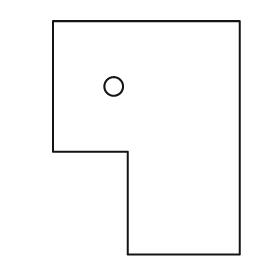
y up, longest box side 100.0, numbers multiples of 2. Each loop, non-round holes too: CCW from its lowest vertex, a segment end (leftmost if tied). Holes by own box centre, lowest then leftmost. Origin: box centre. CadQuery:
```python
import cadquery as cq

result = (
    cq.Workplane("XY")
    .moveTo(-8.0, -50.0)
    .lineTo(40.0, -50.0)
    .lineTo(40.0, 50.0)
    .lineTo(-40.0, 50.0)
    .lineTo(-40.0, -6.0)
    .lineTo(-8.0, -6.0)
    .close()
    .moveTo(-14.0, 22.0)
    .circle(4.0)
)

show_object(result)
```